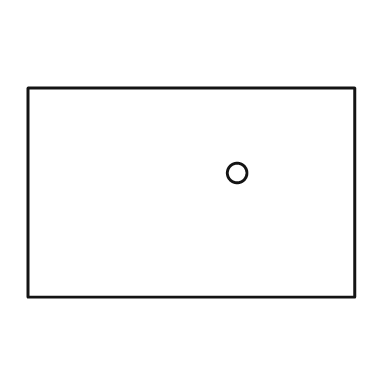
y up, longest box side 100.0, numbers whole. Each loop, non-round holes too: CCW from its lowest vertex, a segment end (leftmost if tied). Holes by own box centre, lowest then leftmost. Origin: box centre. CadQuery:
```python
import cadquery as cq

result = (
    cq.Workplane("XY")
    .moveTo(-50.0, -32.0)
    .lineTo(50.0, -32.0)
    .lineTo(50.0, 32.0)
    .lineTo(-50.0, 32.0)
    .close()
    .moveTo(14.0, 6.0)
    .circle(3.0)
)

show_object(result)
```